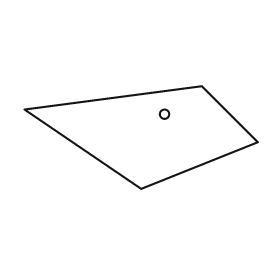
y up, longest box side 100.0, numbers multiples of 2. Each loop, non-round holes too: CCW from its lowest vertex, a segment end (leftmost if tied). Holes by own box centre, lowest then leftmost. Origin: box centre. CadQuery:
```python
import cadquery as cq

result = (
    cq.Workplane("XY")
    .moveTo(0.0, -22.0)
    .lineTo(50.0, -2.0)
    .lineTo(26.0, 22.0)
    .lineTo(-50.0, 12.0)
    .close()
    .moveTo(10.0, 10.0)
    .circle(2.0)
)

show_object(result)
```